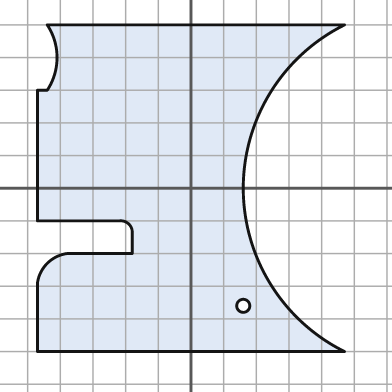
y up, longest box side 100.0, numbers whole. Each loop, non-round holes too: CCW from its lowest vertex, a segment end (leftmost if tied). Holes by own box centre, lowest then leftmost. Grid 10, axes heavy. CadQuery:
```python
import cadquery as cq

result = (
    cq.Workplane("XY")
    .moveTo(-47.0, -50.0)
    .lineTo(47.0, -50.0)
    .threePointArc((16.0, 0.0), (47.0, 50.0))
    .lineTo(-44.0, 50.0)
    .threePointArc((-41.0, 40.0), (-44.0, 30.0))
    .lineTo(-47.0, 30.0)
    .lineTo(-47.0, -10.0)
    .lineTo(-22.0, -10.0)
    .threePointArc((-19.0, -11.0), (-18.0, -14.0))
    .lineTo(-18.0, -20.0)
    .lineTo(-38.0, -20.0)
    .threePointArc((-44.0, -23.0), (-47.0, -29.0))
    .close()
    .moveTo(16.0, -36.0)
    .circle(2.0)
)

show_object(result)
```